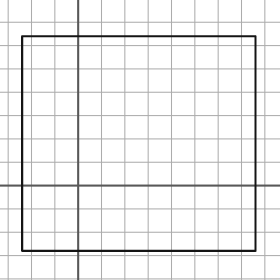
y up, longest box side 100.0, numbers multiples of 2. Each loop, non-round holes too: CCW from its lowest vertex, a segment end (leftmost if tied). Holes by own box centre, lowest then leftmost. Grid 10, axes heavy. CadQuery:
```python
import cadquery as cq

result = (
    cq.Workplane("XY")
    .moveTo(-24.0, -28.0)
    .lineTo(76.0, -28.0)
    .lineTo(76.0, 64.0)
    .lineTo(-24.0, 64.0)
    .close()
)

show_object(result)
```